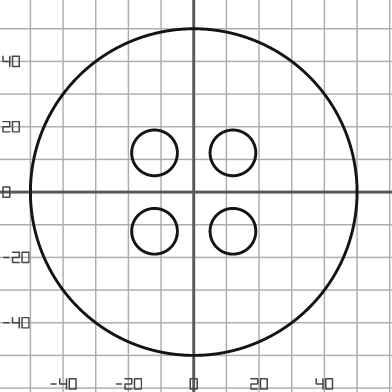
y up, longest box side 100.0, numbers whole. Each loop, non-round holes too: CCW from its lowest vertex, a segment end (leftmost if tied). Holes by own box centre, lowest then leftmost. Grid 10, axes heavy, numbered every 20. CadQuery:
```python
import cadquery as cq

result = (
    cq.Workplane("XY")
    .moveTo(0.0, 0.0)
    .circle(50.0)
    .moveTo(-12.0, -12.0)
    .circle(7.0)
    .moveTo(12.0, -12.0)
    .circle(7.0)
    .moveTo(-12.0, 12.0)
    .circle(7.0)
    .moveTo(12.0, 12.0)
    .circle(7.0)
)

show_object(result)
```